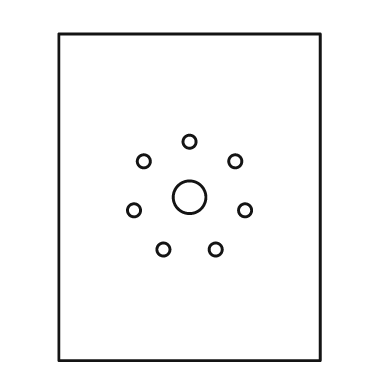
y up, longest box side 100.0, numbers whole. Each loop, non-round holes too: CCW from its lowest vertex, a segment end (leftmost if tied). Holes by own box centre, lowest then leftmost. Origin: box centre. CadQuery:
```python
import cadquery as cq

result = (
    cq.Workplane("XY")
    .moveTo(-40.0, -50.0)
    .lineTo(40.0, -50.0)
    .lineTo(40.0, 50.0)
    .lineTo(-40.0, 50.0)
    .close()
    .moveTo(-8.0, -16.0)
    .circle(2.0)
    .moveTo(8.0, -16.0)
    .circle(2.0)
    .moveTo(-17.0, -4.0)
    .circle(2.0)
    .moveTo(17.0, -4.0)
    .circle(2.0)
    .moveTo(0.0, 0.0)
    .circle(5.0)
    .moveTo(-14.0, 11.0)
    .circle(2.0)
    .moveTo(14.0, 11.0)
    .circle(2.0)
    .moveTo(0.0, 17.0)
    .circle(2.0)
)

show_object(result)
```